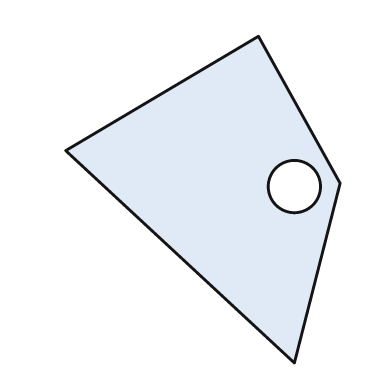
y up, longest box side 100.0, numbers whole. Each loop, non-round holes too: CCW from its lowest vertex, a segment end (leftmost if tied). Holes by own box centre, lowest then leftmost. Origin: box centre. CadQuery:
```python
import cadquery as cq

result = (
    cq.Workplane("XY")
    .moveTo(28.0, -50.0)
    .lineTo(42.0, 5.0)
    .lineTo(17.0, 50.0)
    .lineTo(-42.0, 15.0)
    .close()
    .moveTo(28.0, 4.0)
    .circle(8.0)
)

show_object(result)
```